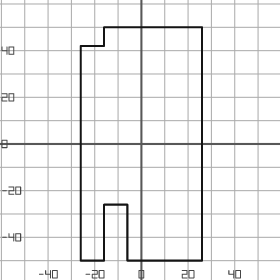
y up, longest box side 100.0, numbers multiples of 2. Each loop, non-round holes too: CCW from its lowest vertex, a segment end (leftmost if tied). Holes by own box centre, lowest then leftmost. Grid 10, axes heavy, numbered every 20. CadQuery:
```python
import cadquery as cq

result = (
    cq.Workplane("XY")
    .moveTo(-26.0, -50.0)
    .lineTo(-16.0, -50.0)
    .lineTo(-16.0, -26.0)
    .lineTo(-6.0, -26.0)
    .lineTo(-6.0, -50.0)
    .lineTo(26.0, -50.0)
    .lineTo(26.0, 50.0)
    .lineTo(-16.0, 50.0)
    .lineTo(-16.0, 42.0)
    .lineTo(-26.0, 42.0)
    .close()
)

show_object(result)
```